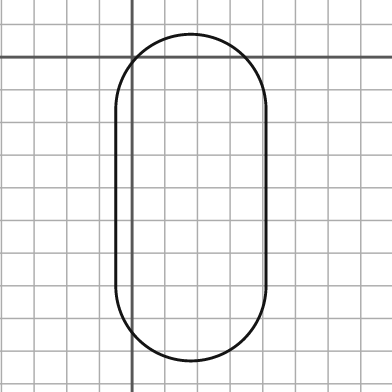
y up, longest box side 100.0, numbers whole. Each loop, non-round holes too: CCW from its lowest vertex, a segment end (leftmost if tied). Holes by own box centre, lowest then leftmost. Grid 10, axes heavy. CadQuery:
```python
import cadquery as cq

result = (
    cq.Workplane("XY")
    .moveTo(-5.0, -70.0)
    .threePointArc((18.0, -93.0), (41.0, -70.0))
    .lineTo(41.0, -16.0)
    .threePointArc((18.0, 7.0), (-5.0, -16.0))
    .close()
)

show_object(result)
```